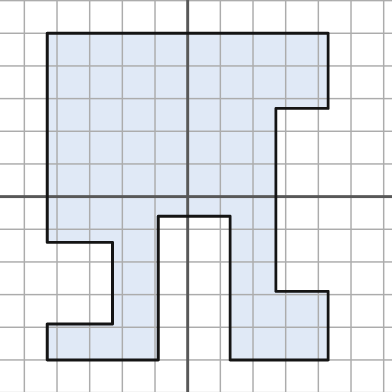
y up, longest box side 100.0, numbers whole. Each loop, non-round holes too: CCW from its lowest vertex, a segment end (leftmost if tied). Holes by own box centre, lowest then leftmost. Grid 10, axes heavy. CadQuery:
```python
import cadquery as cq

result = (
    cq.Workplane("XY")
    .moveTo(-43.0, -50.0)
    .lineTo(-9.0, -50.0)
    .lineTo(-9.0, -6.0)
    .lineTo(13.0, -6.0)
    .lineTo(13.0, -50.0)
    .lineTo(43.0, -50.0)
    .lineTo(43.0, -29.0)
    .lineTo(27.0, -29.0)
    .lineTo(27.0, 27.0)
    .lineTo(43.0, 27.0)
    .lineTo(43.0, 50.0)
    .lineTo(-43.0, 50.0)
    .lineTo(-43.0, -14.0)
    .lineTo(-23.0, -14.0)
    .lineTo(-23.0, -39.0)
    .lineTo(-43.0, -39.0)
    .close()
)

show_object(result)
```